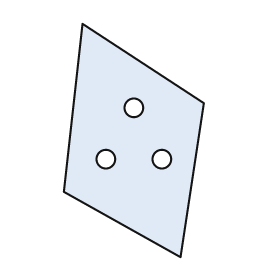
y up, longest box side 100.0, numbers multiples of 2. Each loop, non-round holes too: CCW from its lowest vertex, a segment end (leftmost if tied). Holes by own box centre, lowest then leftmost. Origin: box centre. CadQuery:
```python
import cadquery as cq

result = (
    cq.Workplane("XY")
    .moveTo(20.0, -50.0)
    .lineTo(30.0, 16.0)
    .lineTo(-22.0, 50.0)
    .lineTo(-30.0, -22.0)
    .close()
    .moveTo(-12.0, -8.0)
    .circle(4.0)
    .moveTo(12.0, -8.0)
    .circle(4.0)
    .moveTo(0.0, 14.0)
    .circle(4.0)
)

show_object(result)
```